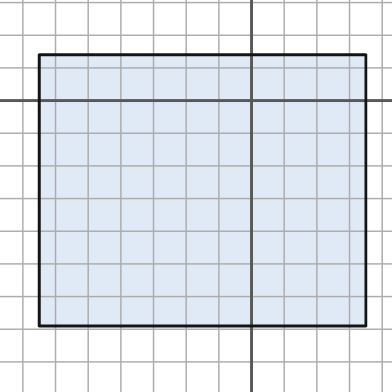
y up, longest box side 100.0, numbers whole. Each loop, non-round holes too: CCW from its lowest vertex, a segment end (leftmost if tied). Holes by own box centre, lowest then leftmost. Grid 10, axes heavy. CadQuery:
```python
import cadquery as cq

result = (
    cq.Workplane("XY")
    .moveTo(-65.0, -69.0)
    .lineTo(35.0, -69.0)
    .lineTo(35.0, 14.0)
    .lineTo(-65.0, 14.0)
    .close()
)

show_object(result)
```